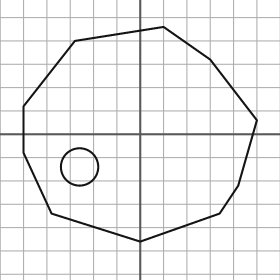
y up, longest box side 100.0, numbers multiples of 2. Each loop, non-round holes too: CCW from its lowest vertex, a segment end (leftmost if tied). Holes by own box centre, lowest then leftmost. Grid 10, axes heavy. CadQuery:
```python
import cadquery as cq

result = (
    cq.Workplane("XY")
    .moveTo(0.0, -46.0)
    .lineTo(34.0, -34.0)
    .lineTo(42.0, -22.0)
    .lineTo(50.0, 6.0)
    .lineTo(30.0, 32.0)
    .lineTo(10.0, 46.0)
    .lineTo(-28.0, 40.0)
    .lineTo(-50.0, 12.0)
    .lineTo(-50.0, -8.0)
    .lineTo(-38.0, -34.0)
    .close()
    .moveTo(-26.0, -14.0)
    .circle(8.0)
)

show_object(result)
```